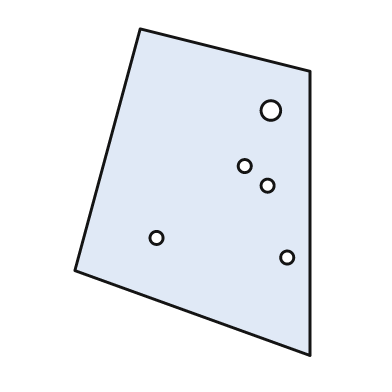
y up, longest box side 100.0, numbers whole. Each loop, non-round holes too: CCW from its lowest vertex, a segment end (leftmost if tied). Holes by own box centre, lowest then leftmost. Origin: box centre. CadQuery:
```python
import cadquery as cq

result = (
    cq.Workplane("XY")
    .moveTo(36.0, -50.0)
    .lineTo(36.0, 37.0)
    .lineTo(-16.0, 50.0)
    .lineTo(-36.0, -24.0)
    .close()
    .moveTo(29.0, -20.0)
    .circle(2.0)
    .moveTo(-11.0, -14.0)
    .circle(2.0)
    .moveTo(23.0, 2.0)
    .circle(2.0)
    .moveTo(16.0, 8.0)
    .circle(2.0)
    .moveTo(24.0, 25.0)
    .circle(3.0)
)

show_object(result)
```